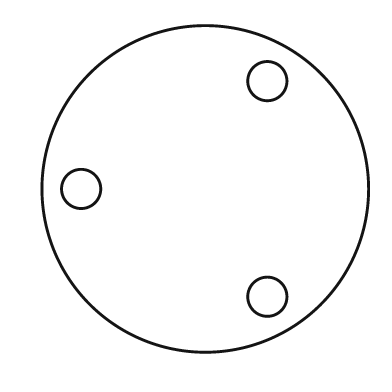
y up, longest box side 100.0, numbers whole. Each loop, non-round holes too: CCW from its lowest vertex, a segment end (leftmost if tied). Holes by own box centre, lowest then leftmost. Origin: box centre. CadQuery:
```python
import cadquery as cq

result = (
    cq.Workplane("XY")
    .moveTo(0.0, 0.0)
    .circle(50.0)
    .moveTo(19.0, -33.0)
    .circle(6.0)
    .moveTo(-38.0, 0.0)
    .circle(6.0)
    .moveTo(19.0, 33.0)
    .circle(6.0)
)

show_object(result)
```